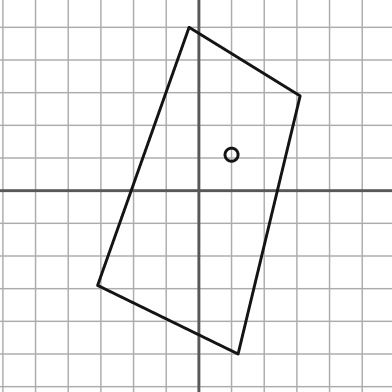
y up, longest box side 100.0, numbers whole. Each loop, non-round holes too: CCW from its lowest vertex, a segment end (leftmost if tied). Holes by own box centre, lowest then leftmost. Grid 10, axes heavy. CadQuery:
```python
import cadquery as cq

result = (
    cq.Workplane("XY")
    .moveTo(12.0, -50.0)
    .lineTo(31.0, 29.0)
    .lineTo(-3.0, 50.0)
    .lineTo(-31.0, -29.0)
    .close()
    .moveTo(10.0, 11.0)
    .circle(2.0)
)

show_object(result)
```